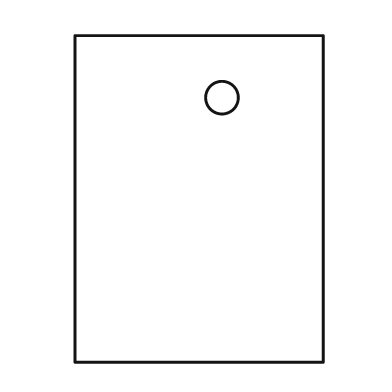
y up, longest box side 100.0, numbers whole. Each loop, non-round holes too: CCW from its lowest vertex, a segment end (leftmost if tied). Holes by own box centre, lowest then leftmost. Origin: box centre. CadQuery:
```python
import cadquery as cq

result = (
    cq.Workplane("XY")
    .moveTo(-38.0, -50.0)
    .lineTo(38.0, -50.0)
    .lineTo(38.0, 50.0)
    .lineTo(-38.0, 50.0)
    .close()
    .moveTo(7.0, 31.0)
    .circle(5.0)
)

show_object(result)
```